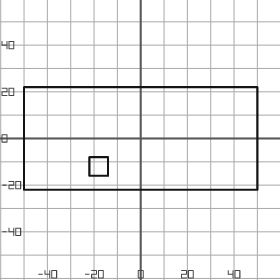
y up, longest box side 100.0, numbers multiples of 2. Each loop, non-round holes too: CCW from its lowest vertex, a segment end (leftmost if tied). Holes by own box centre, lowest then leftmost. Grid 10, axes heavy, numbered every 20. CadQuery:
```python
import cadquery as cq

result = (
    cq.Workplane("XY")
    .moveTo(-50.0, -22.0)
    .lineTo(50.0, -22.0)
    .lineTo(50.0, 22.0)
    .lineTo(-50.0, 22.0)
    .close()
    .moveTo(-22.0, -16.0)
    .lineTo(-14.0, -16.0)
    .lineTo(-14.0, -8.0)
    .lineTo(-22.0, -8.0)
    .close()
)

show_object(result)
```